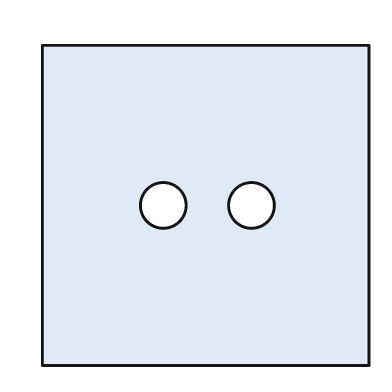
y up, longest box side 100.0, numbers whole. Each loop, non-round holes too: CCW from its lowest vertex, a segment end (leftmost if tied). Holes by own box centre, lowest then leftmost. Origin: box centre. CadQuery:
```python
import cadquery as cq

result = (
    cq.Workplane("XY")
    .moveTo(-50.0, -49.0)
    .lineTo(50.0, -49.0)
    .lineTo(50.0, 49.0)
    .lineTo(-50.0, 49.0)
    .close()
    .moveTo(-13.0, 0.0)
    .circle(7.0)
    .moveTo(14.0, 0.0)
    .circle(7.0)
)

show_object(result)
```